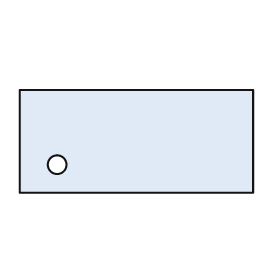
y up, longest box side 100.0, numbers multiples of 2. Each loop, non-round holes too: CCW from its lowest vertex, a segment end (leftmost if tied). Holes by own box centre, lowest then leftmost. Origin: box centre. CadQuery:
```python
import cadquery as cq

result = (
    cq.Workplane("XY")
    .moveTo(-50.0, -22.0)
    .lineTo(50.0, -22.0)
    .lineTo(50.0, 22.0)
    .lineTo(-50.0, 22.0)
    .close()
    .moveTo(-34.0, -10.0)
    .circle(4.0)
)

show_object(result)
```